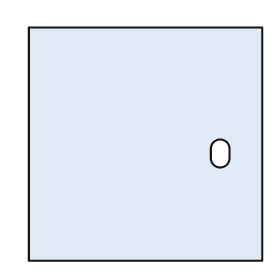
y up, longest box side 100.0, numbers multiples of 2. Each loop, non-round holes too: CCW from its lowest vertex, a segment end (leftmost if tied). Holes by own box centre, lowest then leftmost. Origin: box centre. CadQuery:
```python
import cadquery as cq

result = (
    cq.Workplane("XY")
    .moveTo(-50.0, -50.0)
    .lineTo(50.0, -50.0)
    .lineTo(50.0, 50.0)
    .lineTo(-50.0, 50.0)
    .close()
    .moveTo(28.0, -6.0)
    .threePointArc((32.0, -10.0), (36.0, -6.0))
    .lineTo(36.0, -2.0)
    .threePointArc((32.0, 2.0), (28.0, -2.0))
    .close()
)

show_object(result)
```